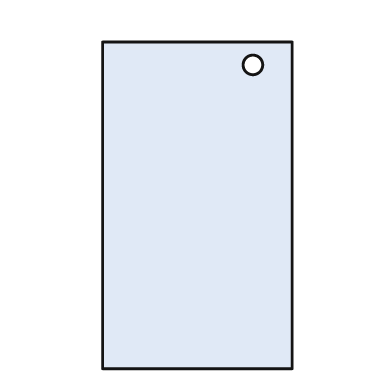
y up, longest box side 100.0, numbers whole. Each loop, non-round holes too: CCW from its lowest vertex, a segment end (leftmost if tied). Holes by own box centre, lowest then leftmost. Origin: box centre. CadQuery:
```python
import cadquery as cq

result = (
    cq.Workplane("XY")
    .moveTo(-29.0, -50.0)
    .lineTo(29.0, -50.0)
    .lineTo(29.0, 50.0)
    .lineTo(-29.0, 50.0)
    .close()
    .moveTo(17.0, 43.0)
    .circle(3.0)
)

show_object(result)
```